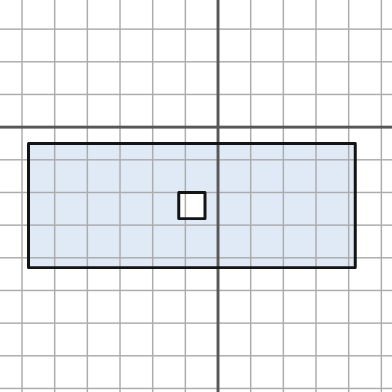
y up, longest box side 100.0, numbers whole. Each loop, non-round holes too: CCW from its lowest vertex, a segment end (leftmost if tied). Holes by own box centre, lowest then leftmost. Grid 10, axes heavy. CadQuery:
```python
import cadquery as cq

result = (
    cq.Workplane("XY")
    .moveTo(-58.0, -43.0)
    .lineTo(42.0, -43.0)
    .lineTo(42.0, -5.0)
    .lineTo(-58.0, -5.0)
    .close()
    .moveTo(-12.0, -28.0)
    .lineTo(-4.0, -28.0)
    .lineTo(-4.0, -20.0)
    .lineTo(-12.0, -20.0)
    .close()
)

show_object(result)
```